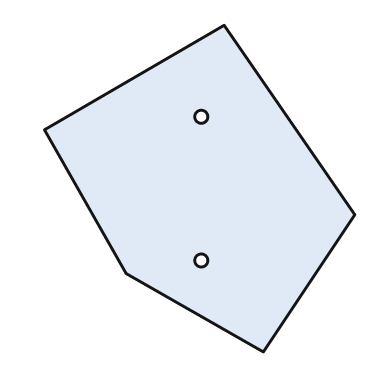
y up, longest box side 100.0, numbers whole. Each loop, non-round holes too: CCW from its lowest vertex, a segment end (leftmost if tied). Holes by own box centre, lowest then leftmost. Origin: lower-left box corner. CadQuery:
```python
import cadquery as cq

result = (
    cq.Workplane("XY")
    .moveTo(67.0, 0.0)
    .lineTo(95.0, 42.0)
    .lineTo(55.0, 100.0)
    .lineTo(0.0, 68.0)
    .lineTo(25.0, 24.0)
    .close()
    .moveTo(48.0, 28.0)
    .circle(2.0)
    .moveTo(48.0, 72.0)
    .circle(2.0)
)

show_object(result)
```